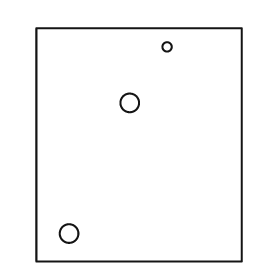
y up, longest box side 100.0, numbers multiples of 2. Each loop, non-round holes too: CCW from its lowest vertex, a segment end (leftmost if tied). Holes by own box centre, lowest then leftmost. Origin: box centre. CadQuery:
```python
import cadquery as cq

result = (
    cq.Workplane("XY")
    .moveTo(-44.0, -50.0)
    .lineTo(44.0, -50.0)
    .lineTo(44.0, 50.0)
    .lineTo(-44.0, 50.0)
    .close()
    .moveTo(-30.0, -38.0)
    .circle(4.0)
    .moveTo(-4.0, 18.0)
    .circle(4.0)
    .moveTo(12.0, 42.0)
    .circle(2.0)
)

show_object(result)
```